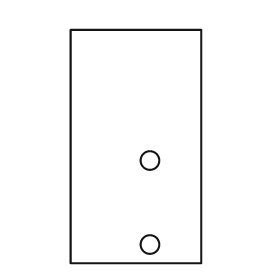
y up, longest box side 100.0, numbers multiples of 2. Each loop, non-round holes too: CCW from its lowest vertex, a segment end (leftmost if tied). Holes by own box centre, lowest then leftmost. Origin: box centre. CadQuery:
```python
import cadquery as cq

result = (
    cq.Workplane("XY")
    .moveTo(-28.0, -50.0)
    .lineTo(28.0, -50.0)
    .lineTo(28.0, 50.0)
    .lineTo(-28.0, 50.0)
    .close()
    .moveTo(6.0, -42.0)
    .circle(4.0)
    .moveTo(6.0, -6.0)
    .circle(4.0)
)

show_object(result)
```